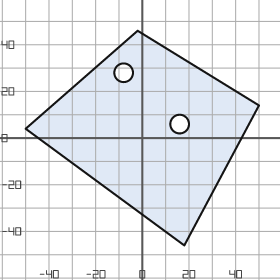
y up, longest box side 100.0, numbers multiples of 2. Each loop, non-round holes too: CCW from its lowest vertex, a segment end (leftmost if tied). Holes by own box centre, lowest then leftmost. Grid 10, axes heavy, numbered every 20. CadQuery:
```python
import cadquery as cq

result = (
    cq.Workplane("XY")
    .moveTo(18.0, -46.0)
    .lineTo(50.0, 14.0)
    .lineTo(-2.0, 46.0)
    .lineTo(-50.0, 4.0)
    .close()
    .moveTo(16.0, 6.0)
    .circle(4.0)
    .moveTo(-8.0, 28.0)
    .circle(4.0)
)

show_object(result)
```